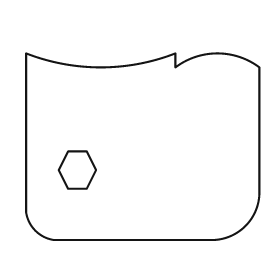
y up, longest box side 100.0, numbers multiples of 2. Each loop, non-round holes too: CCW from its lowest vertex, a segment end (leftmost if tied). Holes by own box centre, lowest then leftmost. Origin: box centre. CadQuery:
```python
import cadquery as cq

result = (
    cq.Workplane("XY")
    .moveTo(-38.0, -40.0)
    .lineTo(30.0, -40.0)
    .threePointArc((44.0, -34.0), (50.0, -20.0))
    .lineTo(50.0, 34.0)
    .threePointArc((32.0, 40.0), (14.0, 34.0))
    .lineTo(14.0, 40.0)
    .threePointArc((-18.0, 34.0), (-50.0, 40.0))
    .lineTo(-50.0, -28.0)
    .threePointArc((-46.0, -36.0), (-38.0, -40.0))
    .close()
    .moveTo(-32.0, -18.0)
    .lineTo(-24.0, -18.0)
    .lineTo(-20.0, -10.0)
    .lineTo(-24.0, -2.0)
    .lineTo(-32.0, -2.0)
    .lineTo(-36.0, -10.0)
    .close()
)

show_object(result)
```